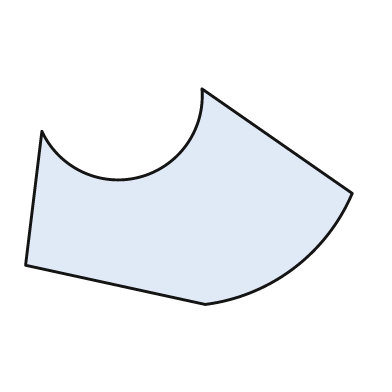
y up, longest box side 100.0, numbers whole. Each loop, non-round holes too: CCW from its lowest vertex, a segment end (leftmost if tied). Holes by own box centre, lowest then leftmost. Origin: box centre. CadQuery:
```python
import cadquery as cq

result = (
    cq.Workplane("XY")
    .moveTo(5.0, -33.0)
    .threePointArc((32.0, -22.0), (50.0, 1.0))
    .lineTo(4.0, 33.0)
    .threePointArc((-15.0, 6.0), (-45.0, 20.0))
    .lineTo(-50.0, -21.0)
    .close()
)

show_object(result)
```